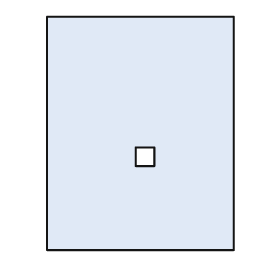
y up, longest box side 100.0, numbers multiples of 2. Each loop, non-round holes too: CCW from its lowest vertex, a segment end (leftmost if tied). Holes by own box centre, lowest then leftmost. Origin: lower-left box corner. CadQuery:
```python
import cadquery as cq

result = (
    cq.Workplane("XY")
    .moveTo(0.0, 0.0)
    .lineTo(80.0, 0.0)
    .lineTo(80.0, 100.0)
    .lineTo(0.0, 100.0)
    .close()
    .moveTo(38.0, 36.0)
    .lineTo(46.0, 36.0)
    .lineTo(46.0, 44.0)
    .lineTo(38.0, 44.0)
    .close()
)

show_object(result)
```